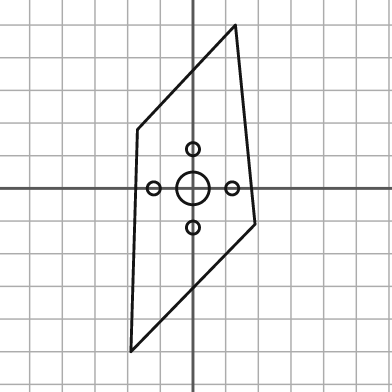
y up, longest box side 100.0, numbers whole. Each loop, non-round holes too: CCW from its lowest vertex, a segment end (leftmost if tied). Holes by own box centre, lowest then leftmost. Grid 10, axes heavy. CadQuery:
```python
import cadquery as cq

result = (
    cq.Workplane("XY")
    .moveTo(-19.0, -50.0)
    .lineTo(19.0, -11.0)
    .lineTo(13.0, 50.0)
    .lineTo(-17.0, 18.0)
    .close()
    .moveTo(0.0, -12.0)
    .circle(2.0)
    .moveTo(-12.0, 0.0)
    .circle(2.0)
    .moveTo(0.0, 0.0)
    .circle(5.0)
    .moveTo(12.0, 0.0)
    .circle(2.0)
    .moveTo(0.0, 12.0)
    .circle(2.0)
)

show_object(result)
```